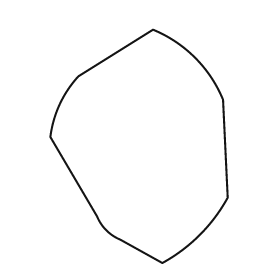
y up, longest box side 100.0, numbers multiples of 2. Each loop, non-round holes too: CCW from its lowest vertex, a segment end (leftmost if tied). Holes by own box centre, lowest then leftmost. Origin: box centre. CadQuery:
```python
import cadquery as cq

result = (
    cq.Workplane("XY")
    .moveTo(10.0, -50.0)
    .threePointArc((26.0, -38.0), (38.0, -22.0))
    .lineTo(36.0, 20.0)
    .threePointArc((24.0, 38.0), (6.0, 50.0))
    .lineTo(-26.0, 30.0)
    .threePointArc((-34.0, 18.0), (-38.0, 4.0))
    .lineTo(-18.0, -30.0)
    .threePointArc((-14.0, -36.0), (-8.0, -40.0))
    .close()
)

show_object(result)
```